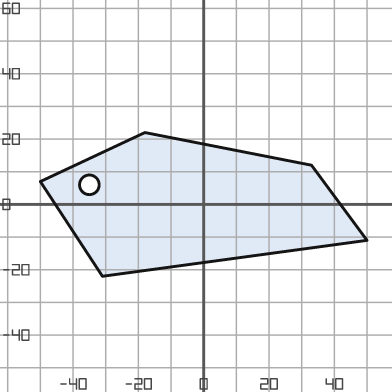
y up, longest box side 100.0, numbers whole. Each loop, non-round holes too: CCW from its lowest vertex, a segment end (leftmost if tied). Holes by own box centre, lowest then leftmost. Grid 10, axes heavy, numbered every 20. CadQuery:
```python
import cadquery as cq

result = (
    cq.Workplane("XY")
    .moveTo(-31.0, -22.0)
    .lineTo(50.0, -11.0)
    .lineTo(33.0, 12.0)
    .lineTo(-18.0, 22.0)
    .lineTo(-50.0, 7.0)
    .close()
    .moveTo(-35.0, 6.0)
    .circle(3.0)
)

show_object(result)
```